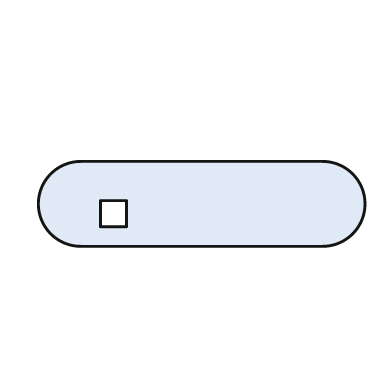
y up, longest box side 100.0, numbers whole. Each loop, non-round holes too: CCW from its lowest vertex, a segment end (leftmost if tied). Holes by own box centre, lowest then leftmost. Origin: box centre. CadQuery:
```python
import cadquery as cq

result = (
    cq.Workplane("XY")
    .moveTo(-37.0, -13.0)
    .lineTo(37.0, -13.0)
    .threePointArc((50.0, 0.0), (37.0, 13.0))
    .lineTo(-37.0, 13.0)
    .threePointArc((-50.0, 0.0), (-37.0, -13.0))
    .close()
    .moveTo(-31.0, -7.0)
    .lineTo(-23.0, -7.0)
    .lineTo(-23.0, 1.0)
    .lineTo(-31.0, 1.0)
    .close()
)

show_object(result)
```